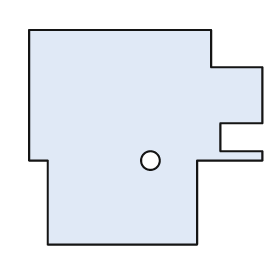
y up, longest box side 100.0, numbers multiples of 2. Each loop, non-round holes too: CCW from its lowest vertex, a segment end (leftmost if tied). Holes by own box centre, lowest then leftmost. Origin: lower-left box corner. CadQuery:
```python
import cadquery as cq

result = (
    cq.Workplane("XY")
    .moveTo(8.0, 0.0)
    .lineTo(72.0, 0.0)
    .lineTo(72.0, 36.0)
    .lineTo(100.0, 36.0)
    .lineTo(100.0, 40.0)
    .lineTo(82.0, 40.0)
    .lineTo(82.0, 52.0)
    .lineTo(100.0, 52.0)
    .lineTo(100.0, 76.0)
    .lineTo(78.0, 76.0)
    .lineTo(78.0, 92.0)
    .lineTo(0.0, 92.0)
    .lineTo(0.0, 36.0)
    .lineTo(8.0, 36.0)
    .close()
    .moveTo(52.0, 36.0)
    .circle(4.0)
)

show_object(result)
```